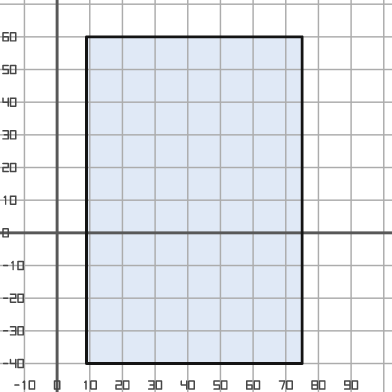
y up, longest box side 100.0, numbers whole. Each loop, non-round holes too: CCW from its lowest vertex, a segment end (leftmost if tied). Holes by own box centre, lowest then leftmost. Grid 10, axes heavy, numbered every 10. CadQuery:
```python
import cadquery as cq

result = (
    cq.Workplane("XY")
    .moveTo(9.0, -40.0)
    .lineTo(75.0, -40.0)
    .lineTo(75.0, 60.0)
    .lineTo(9.0, 60.0)
    .close()
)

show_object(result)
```